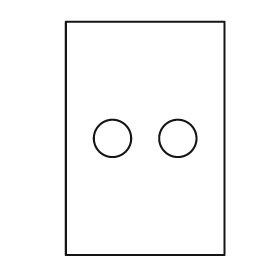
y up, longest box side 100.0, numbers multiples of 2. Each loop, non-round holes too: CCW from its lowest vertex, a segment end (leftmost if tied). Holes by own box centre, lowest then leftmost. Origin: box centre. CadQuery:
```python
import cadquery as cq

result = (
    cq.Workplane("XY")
    .moveTo(-34.0, -50.0)
    .lineTo(34.0, -50.0)
    .lineTo(34.0, 50.0)
    .lineTo(-34.0, 50.0)
    .close()
    .moveTo(-14.0, 0.0)
    .circle(8.0)
    .moveTo(14.0, 0.0)
    .circle(8.0)
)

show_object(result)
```